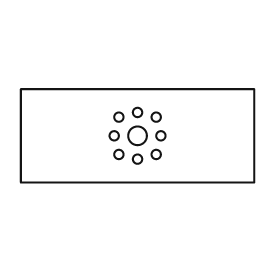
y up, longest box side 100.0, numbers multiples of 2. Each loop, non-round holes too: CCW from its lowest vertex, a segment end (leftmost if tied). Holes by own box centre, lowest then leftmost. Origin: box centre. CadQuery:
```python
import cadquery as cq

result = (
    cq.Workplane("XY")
    .moveTo(-50.0, -20.0)
    .lineTo(50.0, -20.0)
    .lineTo(50.0, 20.0)
    .lineTo(-50.0, 20.0)
    .close()
    .moveTo(0.0, -10.0)
    .circle(2.0)
    .moveTo(-8.0, -8.0)
    .circle(2.0)
    .moveTo(8.0, -8.0)
    .circle(2.0)
    .moveTo(-10.0, 0.0)
    .circle(2.0)
    .moveTo(0.0, 0.0)
    .circle(4.0)
    .moveTo(10.0, 0.0)
    .circle(2.0)
    .moveTo(-8.0, 8.0)
    .circle(2.0)
    .moveTo(8.0, 8.0)
    .circle(2.0)
    .moveTo(0.0, 10.0)
    .circle(2.0)
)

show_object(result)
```